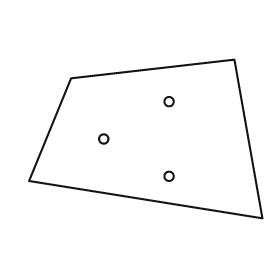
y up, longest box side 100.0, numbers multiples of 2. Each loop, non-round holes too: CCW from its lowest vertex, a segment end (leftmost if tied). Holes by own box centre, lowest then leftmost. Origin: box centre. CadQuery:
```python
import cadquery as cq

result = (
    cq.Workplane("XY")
    .moveTo(50.0, -34.0)
    .lineTo(38.0, 34.0)
    .lineTo(-32.0, 26.0)
    .lineTo(-50.0, -18.0)
    .close()
    .moveTo(10.0, -16.0)
    .circle(2.0)
    .moveTo(-18.0, 0.0)
    .circle(2.0)
    .moveTo(10.0, 16.0)
    .circle(2.0)
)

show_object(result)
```